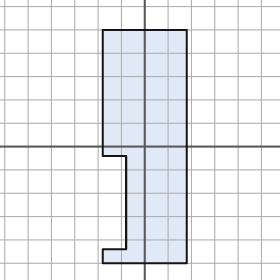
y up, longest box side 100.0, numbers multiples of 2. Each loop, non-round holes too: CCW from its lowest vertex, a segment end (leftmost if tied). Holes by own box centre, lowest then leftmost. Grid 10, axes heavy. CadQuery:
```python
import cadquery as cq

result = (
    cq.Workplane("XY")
    .moveTo(-18.0, -50.0)
    .lineTo(18.0, -50.0)
    .lineTo(18.0, 50.0)
    .lineTo(-18.0, 50.0)
    .lineTo(-18.0, -4.0)
    .lineTo(-8.0, -4.0)
    .lineTo(-8.0, -44.0)
    .lineTo(-18.0, -44.0)
    .close()
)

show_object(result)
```